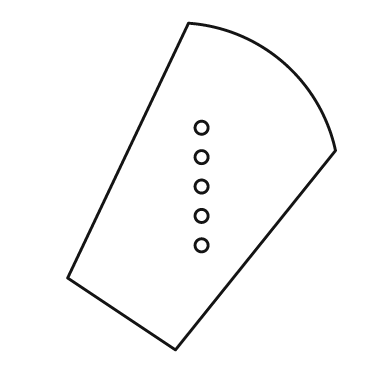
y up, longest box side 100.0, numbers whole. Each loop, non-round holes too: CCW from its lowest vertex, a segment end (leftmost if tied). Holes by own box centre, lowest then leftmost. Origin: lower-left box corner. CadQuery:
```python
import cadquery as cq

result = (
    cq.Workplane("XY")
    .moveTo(33.0, 0.0)
    .lineTo(82.0, 61.0)
    .threePointArc((66.0, 88.0), (37.0, 100.0))
    .lineTo(0.0, 22.0)
    .close()
    .moveTo(41.0, 32.0)
    .circle(2.0)
    .moveTo(41.0, 41.0)
    .circle(2.0)
    .moveTo(41.0, 50.0)
    .circle(2.0)
    .moveTo(41.0, 59.0)
    .circle(2.0)
    .moveTo(41.0, 68.0)
    .circle(2.0)
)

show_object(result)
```